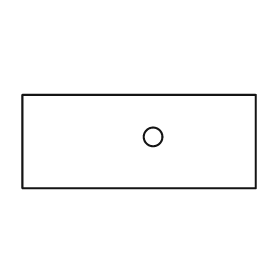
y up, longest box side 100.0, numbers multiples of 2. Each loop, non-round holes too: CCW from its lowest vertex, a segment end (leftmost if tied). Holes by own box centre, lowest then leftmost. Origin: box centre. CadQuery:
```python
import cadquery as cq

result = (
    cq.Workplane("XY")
    .moveTo(-50.0, -20.0)
    .lineTo(50.0, -20.0)
    .lineTo(50.0, 20.0)
    .lineTo(-50.0, 20.0)
    .close()
    .moveTo(6.0, 2.0)
    .circle(4.0)
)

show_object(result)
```